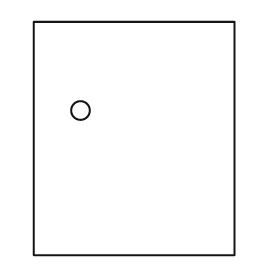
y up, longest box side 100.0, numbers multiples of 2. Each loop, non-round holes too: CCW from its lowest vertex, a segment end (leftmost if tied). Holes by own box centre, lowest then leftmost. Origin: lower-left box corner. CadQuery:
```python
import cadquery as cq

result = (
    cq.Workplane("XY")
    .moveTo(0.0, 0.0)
    .lineTo(86.0, 0.0)
    .lineTo(86.0, 100.0)
    .lineTo(0.0, 100.0)
    .close()
    .moveTo(20.0, 62.0)
    .circle(4.0)
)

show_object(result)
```